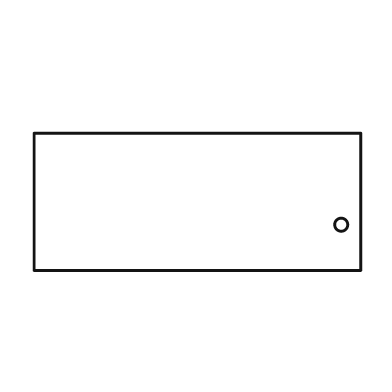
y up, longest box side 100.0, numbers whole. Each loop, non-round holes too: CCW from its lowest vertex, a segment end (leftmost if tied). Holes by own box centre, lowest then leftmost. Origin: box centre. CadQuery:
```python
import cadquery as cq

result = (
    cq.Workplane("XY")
    .moveTo(-50.0, -21.0)
    .lineTo(50.0, -21.0)
    .lineTo(50.0, 21.0)
    .lineTo(-50.0, 21.0)
    .close()
    .moveTo(44.0, -7.0)
    .circle(2.0)
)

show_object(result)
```